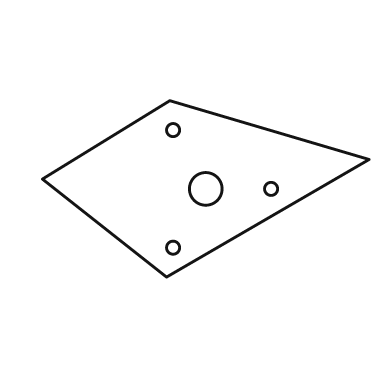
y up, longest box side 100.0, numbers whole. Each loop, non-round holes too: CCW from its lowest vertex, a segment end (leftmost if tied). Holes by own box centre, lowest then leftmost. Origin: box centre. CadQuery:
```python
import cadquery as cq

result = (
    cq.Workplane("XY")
    .moveTo(-12.0, -27.0)
    .lineTo(50.0, 9.0)
    .lineTo(-11.0, 27.0)
    .lineTo(-50.0, 3.0)
    .close()
    .moveTo(-10.0, -18.0)
    .circle(2.0)
    .moveTo(0.0, 0.0)
    .circle(5.0)
    .moveTo(20.0, 0.0)
    .circle(2.0)
    .moveTo(-10.0, 18.0)
    .circle(2.0)
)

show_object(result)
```